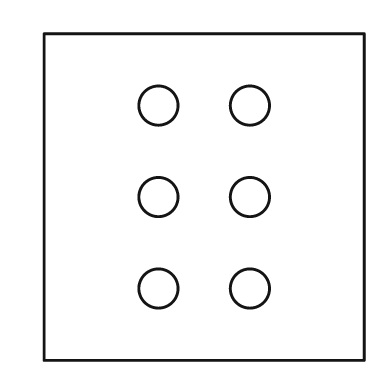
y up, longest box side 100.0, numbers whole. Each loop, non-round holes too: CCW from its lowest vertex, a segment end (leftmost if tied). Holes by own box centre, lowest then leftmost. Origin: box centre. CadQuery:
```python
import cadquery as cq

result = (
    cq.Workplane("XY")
    .moveTo(-49.0, -50.0)
    .lineTo(49.0, -50.0)
    .lineTo(49.0, 50.0)
    .lineTo(-49.0, 50.0)
    .close()
    .moveTo(-14.0, -28.0)
    .circle(6.0)
    .moveTo(14.0, -28.0)
    .circle(6.0)
    .moveTo(-14.0, 0.0)
    .circle(6.0)
    .moveTo(14.0, 0.0)
    .circle(6.0)
    .moveTo(-14.0, 28.0)
    .circle(6.0)
    .moveTo(14.0, 28.0)
    .circle(6.0)
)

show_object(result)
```